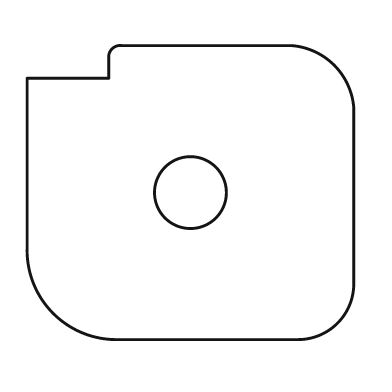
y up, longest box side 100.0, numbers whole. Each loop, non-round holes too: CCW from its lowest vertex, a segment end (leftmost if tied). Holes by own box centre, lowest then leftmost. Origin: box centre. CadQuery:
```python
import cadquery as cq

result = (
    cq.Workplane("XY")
    .moveTo(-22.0, -45.0)
    .lineTo(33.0, -45.0)
    .threePointArc((45.0, -40.0), (50.0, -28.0))
    .lineTo(50.0, 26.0)
    .threePointArc((44.0, 39.0), (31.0, 45.0))
    .lineTo(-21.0, 45.0)
    .threePointArc((-24.0, 44.0), (-25.0, 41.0))
    .lineTo(-25.0, 35.0)
    .lineTo(-50.0, 35.0)
    .lineTo(-50.0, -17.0)
    .threePointArc((-42.0, -37.0), (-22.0, -45.0))
    .close()
    .moveTo(0.0, 0.0)
    .circle(11.0)
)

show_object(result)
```